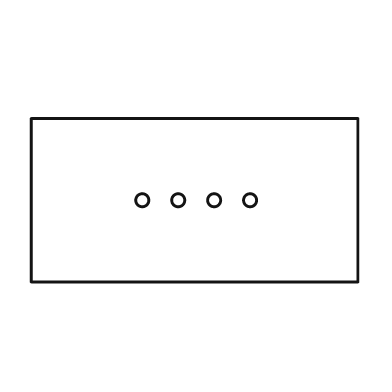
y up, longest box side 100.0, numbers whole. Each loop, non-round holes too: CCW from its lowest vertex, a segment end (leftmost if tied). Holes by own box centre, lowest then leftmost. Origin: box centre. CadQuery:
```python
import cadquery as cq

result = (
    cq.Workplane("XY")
    .moveTo(-50.0, -25.0)
    .lineTo(50.0, -25.0)
    .lineTo(50.0, 25.0)
    .lineTo(-50.0, 25.0)
    .close()
    .moveTo(-16.0, 0.0)
    .circle(2.0)
    .moveTo(-5.0, 0.0)
    .circle(2.0)
    .moveTo(6.0, 0.0)
    .circle(2.0)
    .moveTo(17.0, 0.0)
    .circle(2.0)
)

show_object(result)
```